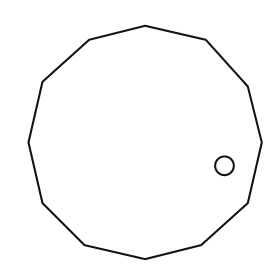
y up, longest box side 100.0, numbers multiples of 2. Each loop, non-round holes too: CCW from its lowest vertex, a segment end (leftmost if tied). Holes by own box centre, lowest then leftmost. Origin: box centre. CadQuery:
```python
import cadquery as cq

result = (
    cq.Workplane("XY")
    .moveTo(0.0, -50.0)
    .lineTo(24.0, -44.0)
    .lineTo(44.0, -26.0)
    .lineTo(50.0, 0.0)
    .lineTo(44.0, 24.0)
    .lineTo(26.0, 44.0)
    .lineTo(0.0, 50.0)
    .lineTo(-24.0, 44.0)
    .lineTo(-44.0, 26.0)
    .lineTo(-50.0, 0.0)
    .lineTo(-44.0, -26.0)
    .lineTo(-26.0, -44.0)
    .close()
    .moveTo(34.0, -10.0)
    .circle(4.0)
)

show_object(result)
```